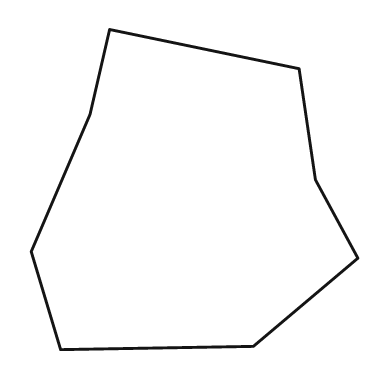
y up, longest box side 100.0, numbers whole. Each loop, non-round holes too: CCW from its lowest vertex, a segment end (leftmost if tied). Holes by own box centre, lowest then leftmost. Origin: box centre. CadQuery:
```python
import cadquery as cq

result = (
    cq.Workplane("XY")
    .moveTo(-41.0, -49.0)
    .lineTo(18.0, -48.0)
    .lineTo(50.0, -21.0)
    .lineTo(37.0, 3.0)
    .lineTo(32.0, 37.0)
    .lineTo(-26.0, 49.0)
    .lineTo(-32.0, 23.0)
    .lineTo(-50.0, -19.0)
    .close()
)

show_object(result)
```